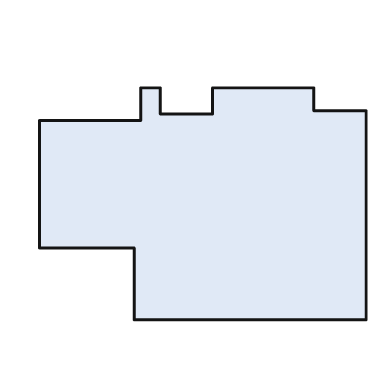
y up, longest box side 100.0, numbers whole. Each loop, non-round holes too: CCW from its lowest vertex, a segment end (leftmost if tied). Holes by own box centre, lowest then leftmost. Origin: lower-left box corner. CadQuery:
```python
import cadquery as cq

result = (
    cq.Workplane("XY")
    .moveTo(29.0, 0.0)
    .lineTo(100.0, 0.0)
    .lineTo(100.0, 64.0)
    .lineTo(84.0, 64.0)
    .lineTo(84.0, 71.0)
    .lineTo(53.0, 71.0)
    .lineTo(53.0, 63.0)
    .lineTo(37.0, 63.0)
    .lineTo(37.0, 71.0)
    .lineTo(31.0, 71.0)
    .lineTo(31.0, 61.0)
    .lineTo(0.0, 61.0)
    .lineTo(0.0, 22.0)
    .lineTo(29.0, 22.0)
    .close()
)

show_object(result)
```